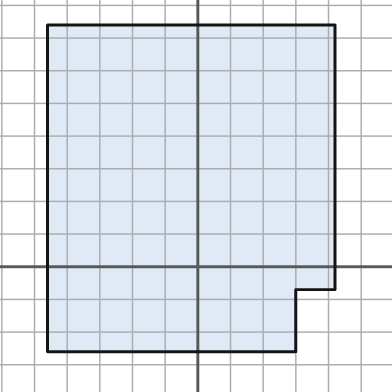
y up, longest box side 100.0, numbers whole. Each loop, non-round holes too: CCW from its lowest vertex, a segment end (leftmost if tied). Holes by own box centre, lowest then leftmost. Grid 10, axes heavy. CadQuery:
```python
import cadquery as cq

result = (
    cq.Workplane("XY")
    .moveTo(-46.0, -26.0)
    .lineTo(30.0, -26.0)
    .lineTo(30.0, -7.0)
    .lineTo(42.0, -7.0)
    .lineTo(42.0, 74.0)
    .lineTo(-46.0, 74.0)
    .close()
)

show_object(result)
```